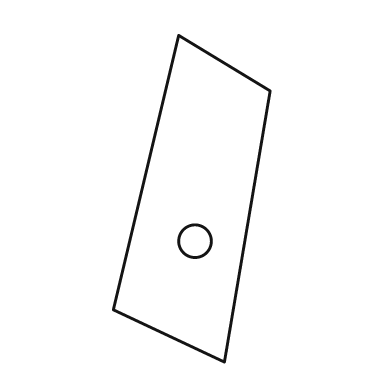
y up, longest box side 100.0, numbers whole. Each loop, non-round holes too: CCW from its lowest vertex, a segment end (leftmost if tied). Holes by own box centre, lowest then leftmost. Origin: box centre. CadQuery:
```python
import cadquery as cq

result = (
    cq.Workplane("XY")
    .moveTo(10.0, -50.0)
    .lineTo(24.0, 33.0)
    .lineTo(-4.0, 50.0)
    .lineTo(-24.0, -34.0)
    .close()
    .moveTo(1.0, -13.0)
    .circle(5.0)
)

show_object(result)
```